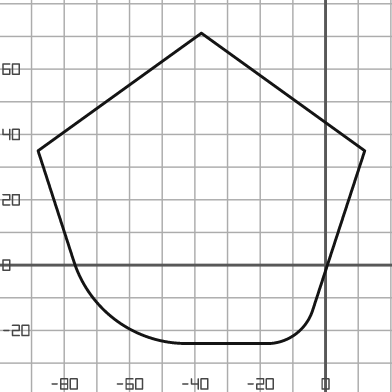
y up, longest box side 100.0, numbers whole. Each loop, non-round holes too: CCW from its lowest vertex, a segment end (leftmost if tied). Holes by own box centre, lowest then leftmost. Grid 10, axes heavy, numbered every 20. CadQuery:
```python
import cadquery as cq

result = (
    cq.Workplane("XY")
    .moveTo(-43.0, -24.0)
    .lineTo(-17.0, -24.0)
    .threePointArc((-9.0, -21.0), (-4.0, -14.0))
    .lineTo(12.0, 35.0)
    .lineTo(-38.0, 71.0)
    .lineTo(-88.0, 35.0)
    .lineTo(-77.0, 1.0)
    .threePointArc((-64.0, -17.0), (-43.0, -24.0))
    .close()
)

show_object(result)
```